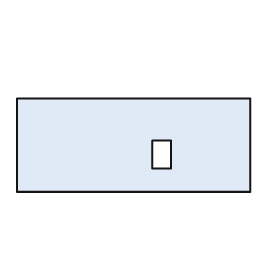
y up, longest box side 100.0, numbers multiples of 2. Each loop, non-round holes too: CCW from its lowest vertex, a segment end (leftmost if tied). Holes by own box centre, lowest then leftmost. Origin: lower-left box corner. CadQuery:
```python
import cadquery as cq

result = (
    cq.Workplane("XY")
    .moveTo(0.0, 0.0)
    .lineTo(100.0, 0.0)
    .lineTo(100.0, 40.0)
    .lineTo(0.0, 40.0)
    .close()
    .moveTo(58.0, 10.0)
    .lineTo(66.0, 10.0)
    .lineTo(66.0, 22.0)
    .lineTo(58.0, 22.0)
    .close()
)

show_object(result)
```